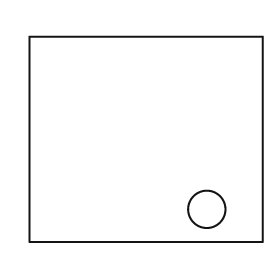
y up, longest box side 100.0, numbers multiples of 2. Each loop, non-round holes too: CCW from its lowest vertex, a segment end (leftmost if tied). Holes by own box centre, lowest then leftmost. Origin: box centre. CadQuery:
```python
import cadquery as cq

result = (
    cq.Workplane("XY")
    .moveTo(-50.0, -44.0)
    .lineTo(50.0, -44.0)
    .lineTo(50.0, 44.0)
    .lineTo(-50.0, 44.0)
    .close()
    .moveTo(26.0, -30.0)
    .circle(8.0)
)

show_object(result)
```